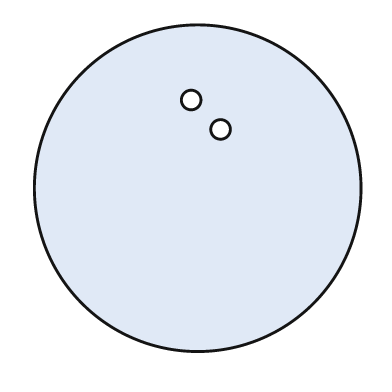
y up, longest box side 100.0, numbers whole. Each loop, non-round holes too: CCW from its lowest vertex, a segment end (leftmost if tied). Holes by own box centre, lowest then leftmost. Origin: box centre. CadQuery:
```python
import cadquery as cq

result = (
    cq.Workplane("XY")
    .moveTo(0.0, 0.0)
    .circle(50.0)
    .moveTo(7.0, 18.0)
    .circle(3.0)
    .moveTo(-2.0, 27.0)
    .circle(3.0)
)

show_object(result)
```